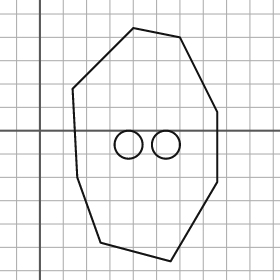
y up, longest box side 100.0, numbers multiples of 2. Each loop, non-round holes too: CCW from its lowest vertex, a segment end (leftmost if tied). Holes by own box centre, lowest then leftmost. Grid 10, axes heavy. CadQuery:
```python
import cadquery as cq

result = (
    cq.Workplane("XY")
    .moveTo(56.0, -56.0)
    .lineTo(76.0, -22.0)
    .lineTo(76.0, 8.0)
    .lineTo(60.0, 40.0)
    .lineTo(40.0, 44.0)
    .lineTo(14.0, 18.0)
    .lineTo(16.0, -20.0)
    .lineTo(26.0, -48.0)
    .close()
    .moveTo(38.0, -6.0)
    .circle(6.0)
    .moveTo(54.0, -6.0)
    .circle(6.0)
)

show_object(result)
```